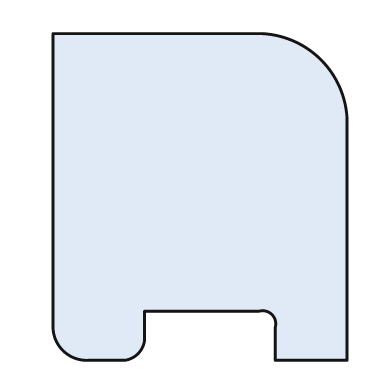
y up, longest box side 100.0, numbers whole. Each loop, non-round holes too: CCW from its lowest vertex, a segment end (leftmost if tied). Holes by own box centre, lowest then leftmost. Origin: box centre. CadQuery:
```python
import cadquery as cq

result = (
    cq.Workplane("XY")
    .moveTo(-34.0, -50.0)
    .lineTo(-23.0, -50.0)
    .threePointArc((-19.0, -48.0), (-17.0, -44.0))
    .lineTo(-17.0, -35.0)
    .lineTo(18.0, -35.0)
    .threePointArc((22.0, -36.0), (23.0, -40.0))
    .lineTo(23.0, -50.0)
    .lineTo(45.0, -50.0)
    .lineTo(45.0, 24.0)
    .threePointArc((37.0, 42.0), (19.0, 50.0))
    .lineTo(-45.0, 50.0)
    .lineTo(-45.0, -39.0)
    .threePointArc((-42.0, -47.0), (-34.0, -50.0))
    .close()
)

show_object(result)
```